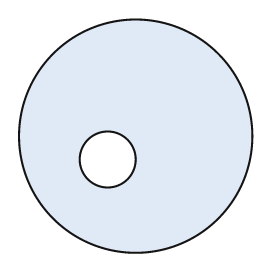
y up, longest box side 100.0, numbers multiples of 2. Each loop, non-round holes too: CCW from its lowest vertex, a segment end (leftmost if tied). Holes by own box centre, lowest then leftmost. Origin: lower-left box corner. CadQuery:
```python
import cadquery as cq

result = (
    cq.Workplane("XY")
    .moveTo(50.0, 50.0)
    .circle(50.0)
    .moveTo(38.0, 40.0)
    .circle(12.0)
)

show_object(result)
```